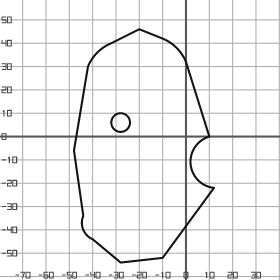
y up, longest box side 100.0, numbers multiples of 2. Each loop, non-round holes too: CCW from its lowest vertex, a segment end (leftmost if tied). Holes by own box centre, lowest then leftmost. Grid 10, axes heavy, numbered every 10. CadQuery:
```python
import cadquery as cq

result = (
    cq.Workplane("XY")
    .moveTo(-28.0, -54.0)
    .lineTo(-10.0, -52.0)
    .lineTo(12.0, -22.0)
    .threePointArc((2.0, -12.0), (10.0, 0.0))
    .lineTo(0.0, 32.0)
    .threePointArc((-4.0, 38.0), (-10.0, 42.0))
    .lineTo(-20.0, 46.0)
    .lineTo(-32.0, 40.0)
    .threePointArc((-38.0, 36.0), (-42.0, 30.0))
    .lineTo(-48.0, -6.0)
    .lineTo(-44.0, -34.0)
    .threePointArc((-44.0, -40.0), (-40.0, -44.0))
    .close()
    .moveTo(-28.0, 6.0)
    .circle(4.0)
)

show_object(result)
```